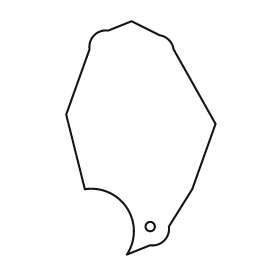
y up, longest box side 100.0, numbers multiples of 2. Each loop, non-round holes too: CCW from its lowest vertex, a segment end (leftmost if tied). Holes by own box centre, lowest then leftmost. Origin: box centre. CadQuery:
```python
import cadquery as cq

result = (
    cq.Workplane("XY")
    .moveTo(-6.0, -50.0)
    .lineTo(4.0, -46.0)
    .threePointArc((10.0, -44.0), (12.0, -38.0))
    .lineTo(22.0, -22.0)
    .lineTo(32.0, 6.0)
    .lineTo(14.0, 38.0)
    .threePointArc((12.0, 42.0), (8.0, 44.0))
    .lineTo(-4.0, 50.0)
    .lineTo(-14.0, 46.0)
    .threePointArc((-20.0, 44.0), (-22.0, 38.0))
    .lineTo(-32.0, 10.0)
    .lineTo(-24.0, -22.0)
    .threePointArc((-6.0, -30.0), (-6.0, -50.0))
    .close()
    .moveTo(4.0, -38.0)
    .circle(2.0)
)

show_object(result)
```